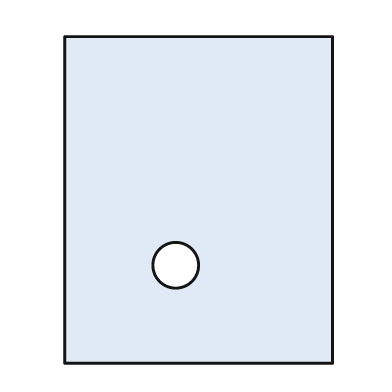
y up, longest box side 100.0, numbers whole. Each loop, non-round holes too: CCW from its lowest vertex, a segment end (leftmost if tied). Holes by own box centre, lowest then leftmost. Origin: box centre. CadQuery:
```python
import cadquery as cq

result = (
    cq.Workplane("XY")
    .moveTo(-41.0, -50.0)
    .lineTo(41.0, -50.0)
    .lineTo(41.0, 50.0)
    .lineTo(-41.0, 50.0)
    .close()
    .moveTo(-7.0, -20.0)
    .circle(7.0)
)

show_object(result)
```